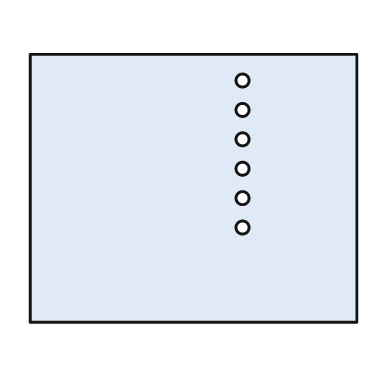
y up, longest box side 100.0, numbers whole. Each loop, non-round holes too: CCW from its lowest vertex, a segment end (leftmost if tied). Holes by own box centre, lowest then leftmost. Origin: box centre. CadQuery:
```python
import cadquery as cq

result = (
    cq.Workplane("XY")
    .moveTo(-50.0, -41.0)
    .lineTo(50.0, -41.0)
    .lineTo(50.0, 41.0)
    .lineTo(-50.0, 41.0)
    .close()
    .moveTo(15.0, -12.0)
    .circle(2.0)
    .moveTo(15.0, -3.0)
    .circle(2.0)
    .moveTo(15.0, 6.0)
    .circle(2.0)
    .moveTo(15.0, 15.0)
    .circle(2.0)
    .moveTo(15.0, 24.0)
    .circle(2.0)
    .moveTo(15.0, 33.0)
    .circle(2.0)
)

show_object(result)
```